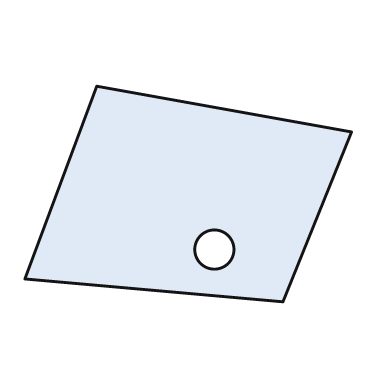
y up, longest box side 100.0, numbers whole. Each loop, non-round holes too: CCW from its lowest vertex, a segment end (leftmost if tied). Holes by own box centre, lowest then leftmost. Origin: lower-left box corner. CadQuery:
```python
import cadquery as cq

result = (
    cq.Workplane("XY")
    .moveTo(79.0, 0.0)
    .lineTo(100.0, 52.0)
    .lineTo(22.0, 66.0)
    .lineTo(0.0, 7.0)
    .close()
    .moveTo(58.0, 16.0)
    .circle(6.0)
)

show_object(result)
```